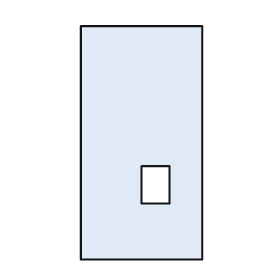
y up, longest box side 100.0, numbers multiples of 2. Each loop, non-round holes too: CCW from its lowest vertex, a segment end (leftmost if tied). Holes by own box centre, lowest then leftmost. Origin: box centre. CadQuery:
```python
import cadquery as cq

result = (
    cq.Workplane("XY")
    .moveTo(-26.0, -50.0)
    .lineTo(26.0, -50.0)
    .lineTo(26.0, 50.0)
    .lineTo(-26.0, 50.0)
    .close()
    .moveTo(0.0, -26.0)
    .lineTo(12.0, -26.0)
    .lineTo(12.0, -10.0)
    .lineTo(0.0, -10.0)
    .close()
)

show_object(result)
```